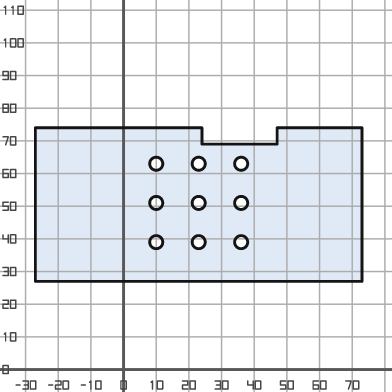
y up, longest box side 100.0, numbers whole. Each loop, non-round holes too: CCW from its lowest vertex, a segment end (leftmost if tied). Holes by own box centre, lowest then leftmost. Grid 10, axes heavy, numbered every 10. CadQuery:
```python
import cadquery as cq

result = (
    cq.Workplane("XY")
    .moveTo(-27.0, 27.0)
    .lineTo(73.0, 27.0)
    .lineTo(73.0, 74.0)
    .lineTo(47.0, 74.0)
    .lineTo(47.0, 69.0)
    .lineTo(24.0, 69.0)
    .lineTo(24.0, 74.0)
    .lineTo(-27.0, 74.0)
    .close()
    .moveTo(10.0, 39.0)
    .circle(2.0)
    .moveTo(23.0, 39.0)
    .circle(2.0)
    .moveTo(36.0, 39.0)
    .circle(2.0)
    .moveTo(10.0, 51.0)
    .circle(2.0)
    .moveTo(23.0, 51.0)
    .circle(2.0)
    .moveTo(36.0, 51.0)
    .circle(2.0)
    .moveTo(10.0, 63.0)
    .circle(2.0)
    .moveTo(23.0, 63.0)
    .circle(2.0)
    .moveTo(36.0, 63.0)
    .circle(2.0)
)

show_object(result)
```